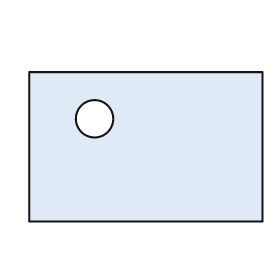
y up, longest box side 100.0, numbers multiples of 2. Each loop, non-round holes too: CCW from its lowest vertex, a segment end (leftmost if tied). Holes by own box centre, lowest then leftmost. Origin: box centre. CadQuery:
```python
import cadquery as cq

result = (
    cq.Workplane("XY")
    .moveTo(-50.0, -32.0)
    .lineTo(50.0, -32.0)
    .lineTo(50.0, 32.0)
    .lineTo(-50.0, 32.0)
    .close()
    .moveTo(-22.0, 12.0)
    .circle(8.0)
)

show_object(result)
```